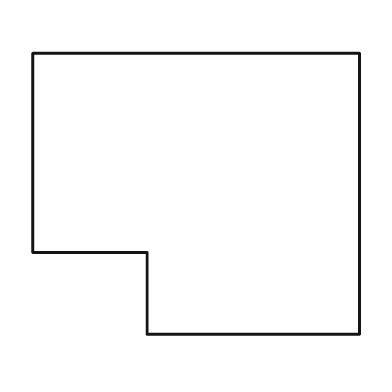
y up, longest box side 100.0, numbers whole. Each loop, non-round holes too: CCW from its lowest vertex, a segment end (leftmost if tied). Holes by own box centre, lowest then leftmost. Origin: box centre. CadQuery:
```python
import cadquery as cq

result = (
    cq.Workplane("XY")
    .moveTo(-15.0, -43.0)
    .lineTo(50.0, -43.0)
    .lineTo(50.0, 43.0)
    .lineTo(-50.0, 43.0)
    .lineTo(-50.0, -18.0)
    .lineTo(-15.0, -18.0)
    .close()
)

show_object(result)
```